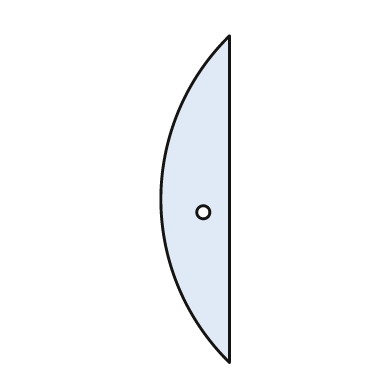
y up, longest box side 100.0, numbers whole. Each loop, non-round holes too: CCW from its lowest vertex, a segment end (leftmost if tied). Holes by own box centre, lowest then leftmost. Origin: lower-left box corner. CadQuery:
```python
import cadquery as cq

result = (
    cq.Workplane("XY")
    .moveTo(21.0, 0.0)
    .lineTo(21.0, 100.0)
    .threePointArc((0.0, 50.0), (21.0, 0.0))
    .close()
    .moveTo(13.0, 46.0)
    .circle(2.0)
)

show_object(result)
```